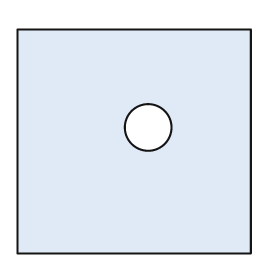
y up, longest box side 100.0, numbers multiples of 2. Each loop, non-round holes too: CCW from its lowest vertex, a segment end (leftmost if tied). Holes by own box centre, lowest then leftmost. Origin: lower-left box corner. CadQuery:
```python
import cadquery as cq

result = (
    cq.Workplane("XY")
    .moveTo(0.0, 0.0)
    .lineTo(100.0, 0.0)
    .lineTo(100.0, 96.0)
    .lineTo(0.0, 96.0)
    .close()
    .moveTo(56.0, 54.0)
    .circle(10.0)
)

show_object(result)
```